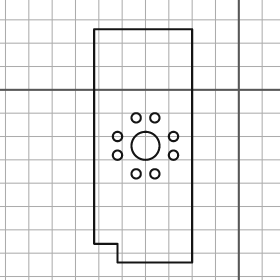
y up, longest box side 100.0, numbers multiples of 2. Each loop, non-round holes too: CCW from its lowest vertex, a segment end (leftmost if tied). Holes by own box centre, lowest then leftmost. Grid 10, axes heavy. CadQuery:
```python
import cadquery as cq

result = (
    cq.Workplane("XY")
    .moveTo(-52.0, -74.0)
    .lineTo(-20.0, -74.0)
    .lineTo(-20.0, 26.0)
    .lineTo(-62.0, 26.0)
    .lineTo(-62.0, -66.0)
    .lineTo(-52.0, -66.0)
    .close()
    .moveTo(-44.0, -36.0)
    .circle(2.0)
    .moveTo(-36.0, -36.0)
    .circle(2.0)
    .moveTo(-52.0, -28.0)
    .circle(2.0)
    .moveTo(-28.0, -28.0)
    .circle(2.0)
    .moveTo(-40.0, -24.0)
    .circle(6.0)
    .moveTo(-52.0, -20.0)
    .circle(2.0)
    .moveTo(-28.0, -20.0)
    .circle(2.0)
    .moveTo(-44.0, -12.0)
    .circle(2.0)
    .moveTo(-36.0, -12.0)
    .circle(2.0)
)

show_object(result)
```